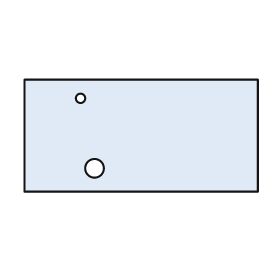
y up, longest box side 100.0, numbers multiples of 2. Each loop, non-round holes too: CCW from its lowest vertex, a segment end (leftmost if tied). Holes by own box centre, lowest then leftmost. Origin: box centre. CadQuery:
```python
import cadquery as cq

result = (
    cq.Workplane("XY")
    .moveTo(-50.0, -24.0)
    .lineTo(50.0, -24.0)
    .lineTo(50.0, 24.0)
    .lineTo(-50.0, 24.0)
    .close()
    .moveTo(-20.0, -14.0)
    .circle(4.0)
    .moveTo(-26.0, 16.0)
    .circle(2.0)
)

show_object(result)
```